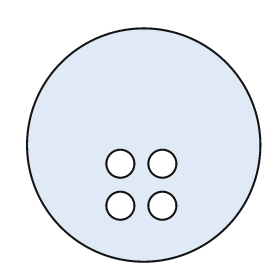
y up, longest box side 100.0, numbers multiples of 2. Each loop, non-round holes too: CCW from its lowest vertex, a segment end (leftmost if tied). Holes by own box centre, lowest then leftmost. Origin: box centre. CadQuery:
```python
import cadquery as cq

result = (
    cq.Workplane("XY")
    .moveTo(0.0, 0.0)
    .circle(50.0)
    .moveTo(-10.0, -26.0)
    .circle(6.0)
    .moveTo(8.0, -26.0)
    .circle(6.0)
    .moveTo(-10.0, -8.0)
    .circle(6.0)
    .moveTo(8.0, -8.0)
    .circle(6.0)
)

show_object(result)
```